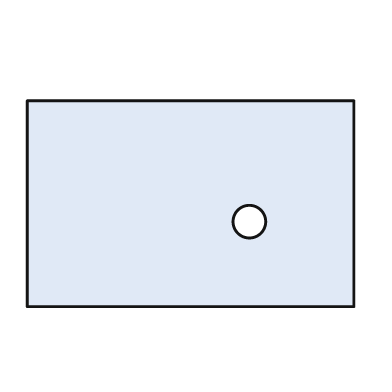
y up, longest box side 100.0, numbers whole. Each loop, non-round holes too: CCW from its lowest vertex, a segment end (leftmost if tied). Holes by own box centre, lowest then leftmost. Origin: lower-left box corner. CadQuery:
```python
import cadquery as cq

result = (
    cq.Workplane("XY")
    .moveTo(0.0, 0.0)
    .lineTo(100.0, 0.0)
    .lineTo(100.0, 63.0)
    .lineTo(0.0, 63.0)
    .close()
    .moveTo(68.0, 26.0)
    .circle(5.0)
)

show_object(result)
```